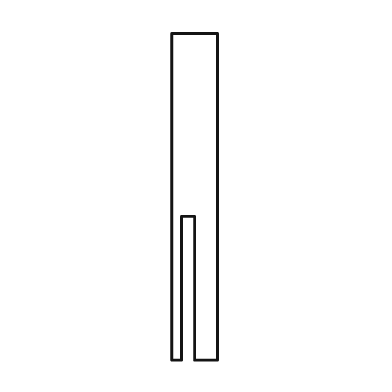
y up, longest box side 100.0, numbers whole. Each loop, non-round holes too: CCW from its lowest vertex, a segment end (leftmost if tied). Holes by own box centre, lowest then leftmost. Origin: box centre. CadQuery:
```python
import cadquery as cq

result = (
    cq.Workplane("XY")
    .moveTo(-7.0, -50.0)
    .lineTo(-4.0, -50.0)
    .lineTo(-4.0, -6.0)
    .lineTo(0.0, -6.0)
    .lineTo(0.0, -50.0)
    .lineTo(7.0, -50.0)
    .lineTo(7.0, 50.0)
    .lineTo(-7.0, 50.0)
    .close()
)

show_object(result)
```